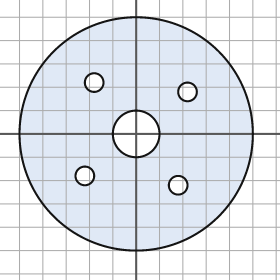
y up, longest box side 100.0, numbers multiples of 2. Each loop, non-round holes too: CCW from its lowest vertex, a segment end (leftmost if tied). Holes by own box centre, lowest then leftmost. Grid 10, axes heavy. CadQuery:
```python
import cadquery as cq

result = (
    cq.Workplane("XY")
    .moveTo(0.0, 0.0)
    .circle(50.0)
    .moveTo(18.0, -22.0)
    .circle(4.0)
    .moveTo(-22.0, -18.0)
    .circle(4.0)
    .moveTo(0.0, 0.0)
    .circle(10.0)
    .moveTo(22.0, 18.0)
    .circle(4.0)
    .moveTo(-18.0, 22.0)
    .circle(4.0)
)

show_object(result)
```